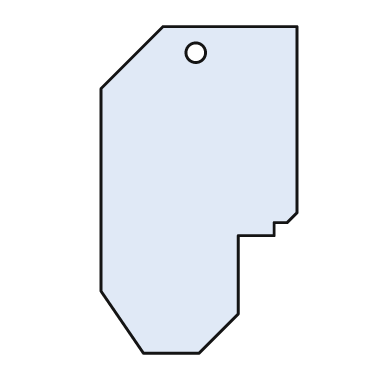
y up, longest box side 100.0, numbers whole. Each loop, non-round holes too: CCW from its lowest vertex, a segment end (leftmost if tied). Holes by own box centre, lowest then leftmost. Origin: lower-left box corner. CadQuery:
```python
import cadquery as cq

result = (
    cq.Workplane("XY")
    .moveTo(13.0, 0.0)
    .lineTo(30.0, 0.0)
    .lineTo(42.0, 12.0)
    .lineTo(42.0, 36.0)
    .lineTo(53.0, 36.0)
    .lineTo(53.0, 40.0)
    .lineTo(57.0, 40.0)
    .lineTo(60.0, 43.0)
    .lineTo(60.0, 100.0)
    .lineTo(19.0, 100.0)
    .lineTo(0.0, 81.0)
    .lineTo(0.0, 19.0)
    .close()
    .moveTo(29.0, 92.0)
    .circle(3.0)
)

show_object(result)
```